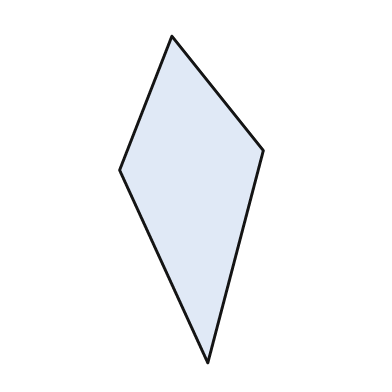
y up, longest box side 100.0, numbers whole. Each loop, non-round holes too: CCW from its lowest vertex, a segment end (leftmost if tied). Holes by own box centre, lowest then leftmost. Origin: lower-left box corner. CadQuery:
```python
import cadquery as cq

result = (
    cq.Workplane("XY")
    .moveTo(27.0, 0.0)
    .lineTo(44.0, 65.0)
    .lineTo(16.0, 100.0)
    .lineTo(0.0, 59.0)
    .close()
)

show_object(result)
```